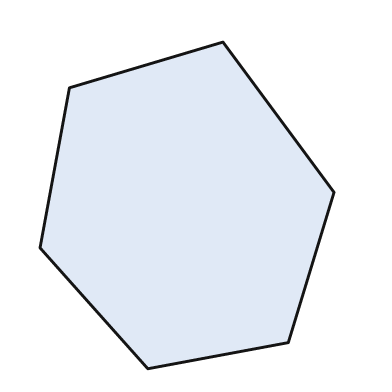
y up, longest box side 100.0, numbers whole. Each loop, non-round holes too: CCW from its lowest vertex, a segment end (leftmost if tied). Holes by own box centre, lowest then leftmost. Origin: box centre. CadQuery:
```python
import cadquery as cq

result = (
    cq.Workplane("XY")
    .moveTo(-12.0, -50.0)
    .lineTo(31.0, -42.0)
    .lineTo(45.0, 4.0)
    .lineTo(11.0, 50.0)
    .lineTo(-36.0, 36.0)
    .lineTo(-45.0, -13.0)
    .close()
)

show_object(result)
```